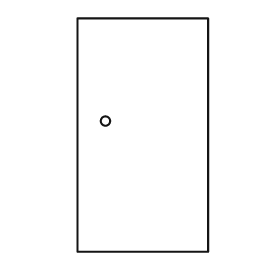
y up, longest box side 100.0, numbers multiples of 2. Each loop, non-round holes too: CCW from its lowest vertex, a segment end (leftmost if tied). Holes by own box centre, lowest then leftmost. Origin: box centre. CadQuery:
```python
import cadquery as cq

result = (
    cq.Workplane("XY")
    .moveTo(-28.0, -50.0)
    .lineTo(28.0, -50.0)
    .lineTo(28.0, 50.0)
    .lineTo(-28.0, 50.0)
    .close()
    .moveTo(-16.0, 6.0)
    .circle(2.0)
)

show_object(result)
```